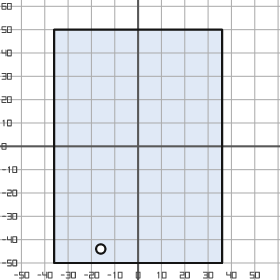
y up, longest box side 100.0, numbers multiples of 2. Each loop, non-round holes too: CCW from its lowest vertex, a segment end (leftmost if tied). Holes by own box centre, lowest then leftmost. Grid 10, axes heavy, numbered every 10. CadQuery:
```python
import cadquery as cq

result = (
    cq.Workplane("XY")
    .moveTo(-36.0, -50.0)
    .lineTo(36.0, -50.0)
    .lineTo(36.0, 50.0)
    .lineTo(-36.0, 50.0)
    .close()
    .moveTo(-16.0, -44.0)
    .circle(2.0)
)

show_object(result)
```